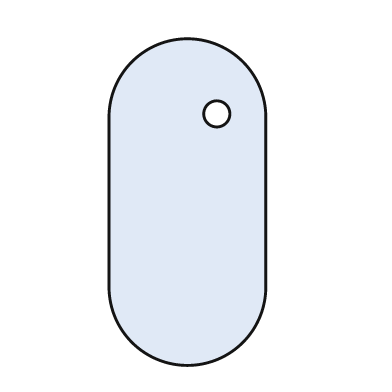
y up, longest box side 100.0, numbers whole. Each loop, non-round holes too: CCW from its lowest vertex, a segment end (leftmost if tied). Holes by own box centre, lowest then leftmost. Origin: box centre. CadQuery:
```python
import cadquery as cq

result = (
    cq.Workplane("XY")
    .moveTo(-24.0, -26.0)
    .threePointArc((0.0, -50.0), (24.0, -26.0))
    .lineTo(24.0, 26.0)
    .threePointArc((0.0, 50.0), (-24.0, 26.0))
    .close()
    .moveTo(9.0, 27.0)
    .circle(4.0)
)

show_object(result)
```